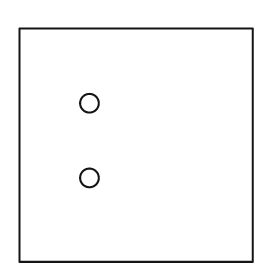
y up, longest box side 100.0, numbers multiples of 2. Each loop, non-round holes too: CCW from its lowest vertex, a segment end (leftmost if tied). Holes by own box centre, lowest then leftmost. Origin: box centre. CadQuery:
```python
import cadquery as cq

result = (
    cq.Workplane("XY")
    .moveTo(-50.0, -50.0)
    .lineTo(50.0, -50.0)
    .lineTo(50.0, 50.0)
    .lineTo(-50.0, 50.0)
    .close()
    .moveTo(-20.0, -14.0)
    .circle(4.0)
    .moveTo(-20.0, 18.0)
    .circle(4.0)
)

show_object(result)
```